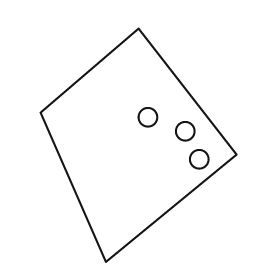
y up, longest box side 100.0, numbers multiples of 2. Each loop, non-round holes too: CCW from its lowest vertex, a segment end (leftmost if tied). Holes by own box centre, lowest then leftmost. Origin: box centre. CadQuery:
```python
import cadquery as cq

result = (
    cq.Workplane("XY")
    .moveTo(-14.0, -50.0)
    .lineTo(42.0, -4.0)
    .lineTo(0.0, 50.0)
    .lineTo(-42.0, 14.0)
    .close()
    .moveTo(26.0, -6.0)
    .circle(4.0)
    .moveTo(20.0, 6.0)
    .circle(4.0)
    .moveTo(4.0, 12.0)
    .circle(4.0)
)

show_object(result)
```